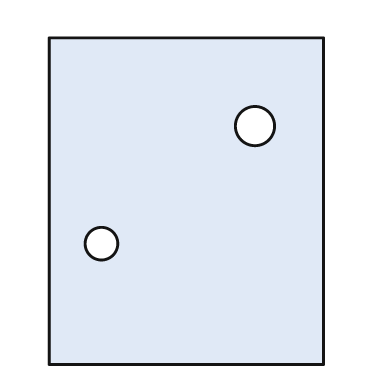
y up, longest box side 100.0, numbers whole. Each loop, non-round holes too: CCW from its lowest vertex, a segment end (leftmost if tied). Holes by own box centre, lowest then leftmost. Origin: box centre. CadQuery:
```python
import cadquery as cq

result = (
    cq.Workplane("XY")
    .moveTo(-42.0, -50.0)
    .lineTo(42.0, -50.0)
    .lineTo(42.0, 50.0)
    .lineTo(-42.0, 50.0)
    .close()
    .moveTo(-26.0, -13.0)
    .circle(5.0)
    .moveTo(21.0, 23.0)
    .circle(6.0)
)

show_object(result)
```